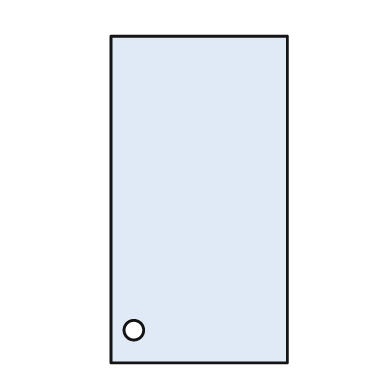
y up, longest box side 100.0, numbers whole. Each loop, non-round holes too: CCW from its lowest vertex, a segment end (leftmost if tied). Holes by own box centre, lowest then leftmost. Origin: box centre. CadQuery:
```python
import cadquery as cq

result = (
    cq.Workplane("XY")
    .moveTo(-27.0, -50.0)
    .lineTo(27.0, -50.0)
    .lineTo(27.0, 50.0)
    .lineTo(-27.0, 50.0)
    .close()
    .moveTo(-20.0, -40.0)
    .circle(3.0)
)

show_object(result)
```